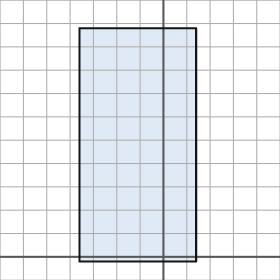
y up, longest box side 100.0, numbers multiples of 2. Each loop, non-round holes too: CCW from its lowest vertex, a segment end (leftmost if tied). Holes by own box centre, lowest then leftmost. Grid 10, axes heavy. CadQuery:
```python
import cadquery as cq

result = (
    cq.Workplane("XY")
    .moveTo(-36.0, -2.0)
    .lineTo(14.0, -2.0)
    .lineTo(14.0, 98.0)
    .lineTo(-36.0, 98.0)
    .close()
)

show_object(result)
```